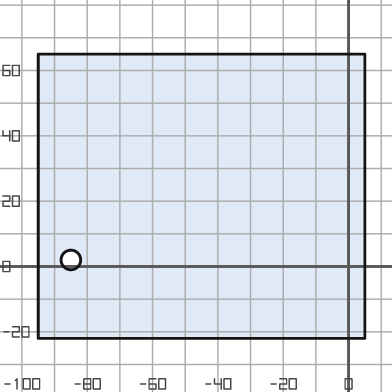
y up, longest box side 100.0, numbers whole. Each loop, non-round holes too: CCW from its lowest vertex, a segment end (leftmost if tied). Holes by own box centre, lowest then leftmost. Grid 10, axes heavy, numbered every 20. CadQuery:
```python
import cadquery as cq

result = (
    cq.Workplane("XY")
    .moveTo(-95.0, -22.0)
    .lineTo(5.0, -22.0)
    .lineTo(5.0, 65.0)
    .lineTo(-95.0, 65.0)
    .close()
    .moveTo(-85.0, 2.0)
    .circle(3.0)
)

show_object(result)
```